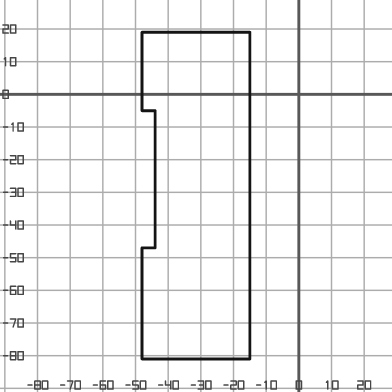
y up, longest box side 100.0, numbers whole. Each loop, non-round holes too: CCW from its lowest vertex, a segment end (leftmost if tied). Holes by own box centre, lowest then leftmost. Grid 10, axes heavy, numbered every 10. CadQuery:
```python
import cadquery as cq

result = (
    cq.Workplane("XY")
    .moveTo(-48.0, -81.0)
    .lineTo(-15.0, -81.0)
    .lineTo(-15.0, 19.0)
    .lineTo(-48.0, 19.0)
    .lineTo(-48.0, -5.0)
    .lineTo(-44.0, -5.0)
    .lineTo(-44.0, -47.0)
    .lineTo(-48.0, -47.0)
    .close()
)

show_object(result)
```